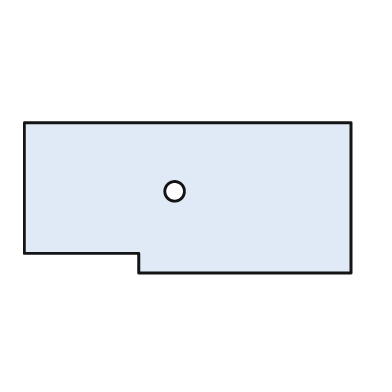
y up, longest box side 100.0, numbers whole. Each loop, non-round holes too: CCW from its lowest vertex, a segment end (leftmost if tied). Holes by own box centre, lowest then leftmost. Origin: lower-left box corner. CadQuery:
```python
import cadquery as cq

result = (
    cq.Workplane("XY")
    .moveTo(35.0, 0.0)
    .lineTo(100.0, 0.0)
    .lineTo(100.0, 46.0)
    .lineTo(0.0, 46.0)
    .lineTo(0.0, 6.0)
    .lineTo(35.0, 6.0)
    .close()
    .moveTo(46.0, 25.0)
    .circle(3.0)
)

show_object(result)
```